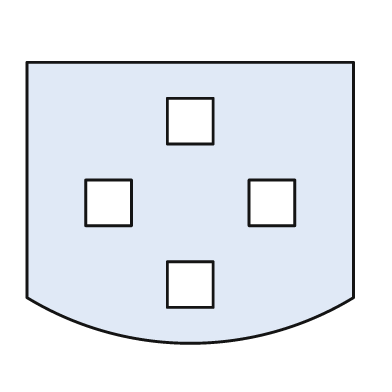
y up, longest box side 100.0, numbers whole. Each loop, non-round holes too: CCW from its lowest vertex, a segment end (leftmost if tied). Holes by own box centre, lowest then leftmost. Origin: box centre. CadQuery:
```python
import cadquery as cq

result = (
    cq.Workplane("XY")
    .moveTo(-50.0, -29.0)
    .threePointArc((0.0, -43.0), (50.0, -29.0))
    .lineTo(50.0, 43.0)
    .lineTo(-50.0, 43.0)
    .close()
    .moveTo(-7.0, -32.0)
    .lineTo(7.0, -32.0)
    .lineTo(7.0, -18.0)
    .lineTo(-7.0, -18.0)
    .close()
    .moveTo(-32.0, -7.0)
    .lineTo(-18.0, -7.0)
    .lineTo(-18.0, 7.0)
    .lineTo(-32.0, 7.0)
    .close()
    .moveTo(18.0, -7.0)
    .lineTo(32.0, -7.0)
    .lineTo(32.0, 7.0)
    .lineTo(18.0, 7.0)
    .close()
    .moveTo(-7.0, 18.0)
    .lineTo(7.0, 18.0)
    .lineTo(7.0, 32.0)
    .lineTo(-7.0, 32.0)
    .close()
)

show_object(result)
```